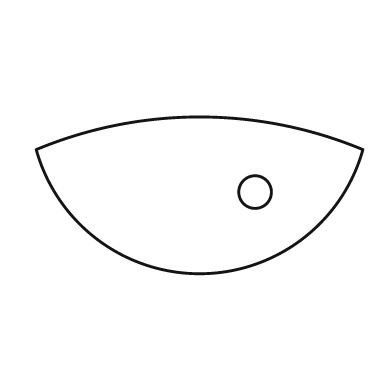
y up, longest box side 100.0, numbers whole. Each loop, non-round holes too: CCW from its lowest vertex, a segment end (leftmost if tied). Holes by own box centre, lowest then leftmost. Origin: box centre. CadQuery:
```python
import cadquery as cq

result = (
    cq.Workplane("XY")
    .moveTo(-50.0, 14.0)
    .threePointArc((0.0, -24.0), (50.0, 14.0))
    .threePointArc((0.0, 24.0), (-50.0, 14.0))
    .close()
    .moveTo(17.0, 1.0)
    .circle(5.0)
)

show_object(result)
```